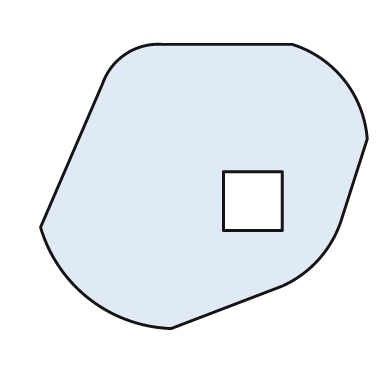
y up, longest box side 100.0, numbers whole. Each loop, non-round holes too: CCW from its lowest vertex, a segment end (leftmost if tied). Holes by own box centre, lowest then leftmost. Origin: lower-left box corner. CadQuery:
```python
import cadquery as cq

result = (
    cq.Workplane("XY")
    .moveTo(40.0, 0.0)
    .lineTo(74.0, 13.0)
    .threePointArc((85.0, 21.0), (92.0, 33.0))
    .lineTo(100.0, 58.0)
    .threePointArc((93.0, 76.0), (77.0, 87.0))
    .lineTo(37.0, 87.0)
    .threePointArc((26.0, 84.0), (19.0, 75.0))
    .lineTo(0.0, 31.0)
    .threePointArc((15.0, 9.0), (40.0, 0.0))
    .close()
    .moveTo(56.0, 30.0)
    .lineTo(74.0, 30.0)
    .lineTo(74.0, 48.0)
    .lineTo(56.0, 48.0)
    .close()
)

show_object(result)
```